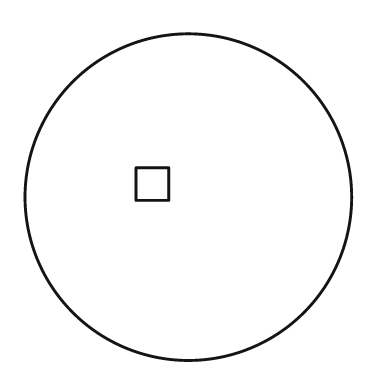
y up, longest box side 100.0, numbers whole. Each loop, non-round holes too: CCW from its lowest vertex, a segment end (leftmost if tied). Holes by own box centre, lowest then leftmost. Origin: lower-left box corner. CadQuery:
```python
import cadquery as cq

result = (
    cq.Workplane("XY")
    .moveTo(50.0, 50.0)
    .circle(50.0)
    .moveTo(34.0, 49.0)
    .lineTo(44.0, 49.0)
    .lineTo(44.0, 59.0)
    .lineTo(34.0, 59.0)
    .close()
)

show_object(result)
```